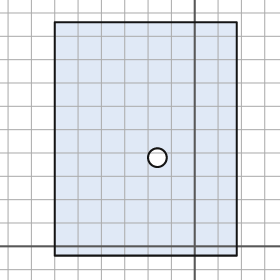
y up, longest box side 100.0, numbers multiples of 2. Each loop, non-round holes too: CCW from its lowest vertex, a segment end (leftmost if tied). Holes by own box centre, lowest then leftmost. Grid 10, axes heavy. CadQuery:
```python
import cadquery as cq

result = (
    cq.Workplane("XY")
    .moveTo(-60.0, -4.0)
    .lineTo(18.0, -4.0)
    .lineTo(18.0, 96.0)
    .lineTo(-60.0, 96.0)
    .close()
    .moveTo(-16.0, 38.0)
    .circle(4.0)
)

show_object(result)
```